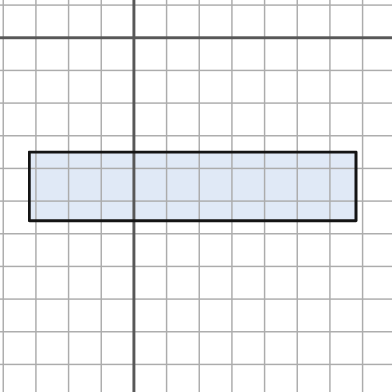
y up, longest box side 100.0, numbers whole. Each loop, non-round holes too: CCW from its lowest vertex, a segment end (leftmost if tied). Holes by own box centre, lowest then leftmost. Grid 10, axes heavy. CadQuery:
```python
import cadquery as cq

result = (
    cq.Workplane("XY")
    .moveTo(-32.0, -56.0)
    .lineTo(68.0, -56.0)
    .lineTo(68.0, -35.0)
    .lineTo(-32.0, -35.0)
    .close()
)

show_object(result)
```